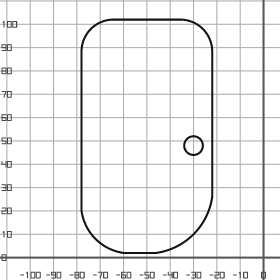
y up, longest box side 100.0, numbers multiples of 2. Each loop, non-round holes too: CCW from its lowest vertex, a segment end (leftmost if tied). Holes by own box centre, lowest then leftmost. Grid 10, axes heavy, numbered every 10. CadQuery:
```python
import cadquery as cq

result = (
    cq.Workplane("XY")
    .moveTo(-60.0, 2.0)
    .lineTo(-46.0, 2.0)
    .threePointArc((-30.0, 10.0), (-22.0, 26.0))
    .lineTo(-22.0, 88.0)
    .threePointArc((-26.0, 98.0), (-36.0, 102.0))
    .lineTo(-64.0, 102.0)
    .threePointArc((-74.0, 98.0), (-78.0, 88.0))
    .lineTo(-78.0, 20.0)
    .threePointArc((-72.0, 8.0), (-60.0, 2.0))
    .close()
    .moveTo(-30.0, 48.0)
    .circle(4.0)
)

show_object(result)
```